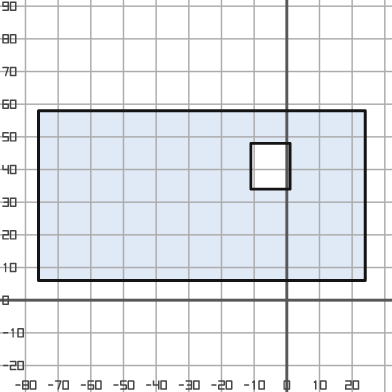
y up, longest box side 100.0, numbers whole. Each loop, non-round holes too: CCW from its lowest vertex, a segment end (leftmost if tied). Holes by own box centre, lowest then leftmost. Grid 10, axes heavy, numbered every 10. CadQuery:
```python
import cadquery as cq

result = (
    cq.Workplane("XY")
    .moveTo(-76.0, 6.0)
    .lineTo(24.0, 6.0)
    .lineTo(24.0, 58.0)
    .lineTo(-76.0, 58.0)
    .close()
    .moveTo(-11.0, 34.0)
    .lineTo(1.0, 34.0)
    .lineTo(1.0, 48.0)
    .lineTo(-11.0, 48.0)
    .close()
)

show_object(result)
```